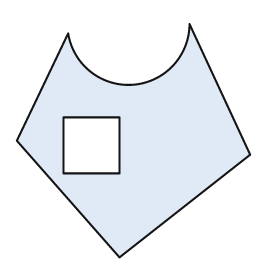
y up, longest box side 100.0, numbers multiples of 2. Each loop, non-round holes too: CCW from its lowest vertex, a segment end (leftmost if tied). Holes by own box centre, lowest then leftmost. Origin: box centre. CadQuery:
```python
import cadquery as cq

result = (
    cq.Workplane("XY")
    .moveTo(-6.0, -50.0)
    .lineTo(50.0, -6.0)
    .lineTo(24.0, 50.0)
    .threePointArc((0.0, 24.0), (-28.0, 46.0))
    .lineTo(-50.0, 0.0)
    .close()
    .moveTo(-30.0, -14.0)
    .lineTo(-6.0, -14.0)
    .lineTo(-6.0, 10.0)
    .lineTo(-30.0, 10.0)
    .close()
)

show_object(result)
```